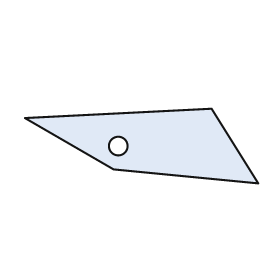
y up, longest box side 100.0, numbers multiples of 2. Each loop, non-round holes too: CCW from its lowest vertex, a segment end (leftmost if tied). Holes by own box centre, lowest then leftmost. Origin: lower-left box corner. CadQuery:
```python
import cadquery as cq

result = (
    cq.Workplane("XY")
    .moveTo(100.0, 0.0)
    .lineTo(80.0, 32.0)
    .lineTo(0.0, 28.0)
    .lineTo(38.0, 6.0)
    .close()
    .moveTo(40.0, 16.0)
    .circle(4.0)
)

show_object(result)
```